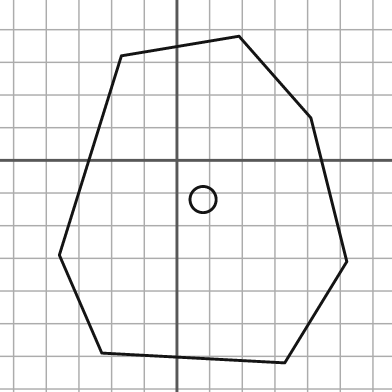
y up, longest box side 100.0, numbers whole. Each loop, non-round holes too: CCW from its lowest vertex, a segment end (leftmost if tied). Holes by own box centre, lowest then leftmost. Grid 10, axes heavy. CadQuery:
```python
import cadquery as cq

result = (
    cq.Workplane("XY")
    .moveTo(33.0, -62.0)
    .lineTo(52.0, -31.0)
    .lineTo(41.0, 13.0)
    .lineTo(19.0, 38.0)
    .lineTo(-17.0, 32.0)
    .lineTo(-36.0, -29.0)
    .lineTo(-23.0, -59.0)
    .close()
    .moveTo(8.0, -12.0)
    .circle(4.0)
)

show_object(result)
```